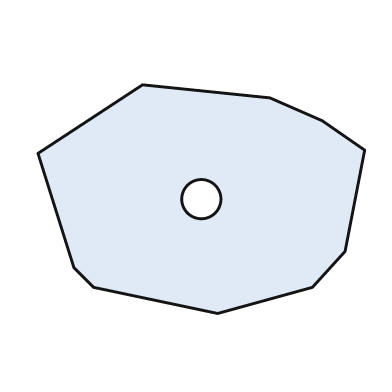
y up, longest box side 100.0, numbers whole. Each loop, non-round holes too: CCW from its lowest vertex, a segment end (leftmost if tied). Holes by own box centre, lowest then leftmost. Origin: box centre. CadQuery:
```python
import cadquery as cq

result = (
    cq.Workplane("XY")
    .moveTo(5.0, -35.0)
    .lineTo(34.0, -27.0)
    .lineTo(44.0, -16.0)
    .lineTo(50.0, 15.0)
    .lineTo(37.0, 24.0)
    .lineTo(21.0, 31.0)
    .lineTo(-18.0, 35.0)
    .lineTo(-50.0, 14.0)
    .lineTo(-39.0, -21.0)
    .lineTo(-33.0, -27.0)
    .close()
    .moveTo(0.0, 0.0)
    .circle(6.0)
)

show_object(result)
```